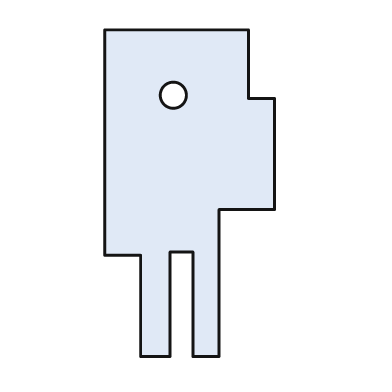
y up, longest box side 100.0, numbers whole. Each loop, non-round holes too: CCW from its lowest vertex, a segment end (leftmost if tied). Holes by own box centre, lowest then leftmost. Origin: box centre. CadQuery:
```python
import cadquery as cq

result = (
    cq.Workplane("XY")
    .moveTo(-15.0, -50.0)
    .lineTo(-6.0, -50.0)
    .lineTo(-6.0, -18.0)
    .lineTo(1.0, -18.0)
    .lineTo(1.0, -50.0)
    .lineTo(9.0, -50.0)
    .lineTo(9.0, -5.0)
    .lineTo(26.0, -5.0)
    .lineTo(26.0, 29.0)
    .lineTo(18.0, 29.0)
    .lineTo(18.0, 50.0)
    .lineTo(-26.0, 50.0)
    .lineTo(-26.0, -19.0)
    .lineTo(-15.0, -19.0)
    .close()
    .moveTo(-5.0, 30.0)
    .circle(4.0)
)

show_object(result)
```